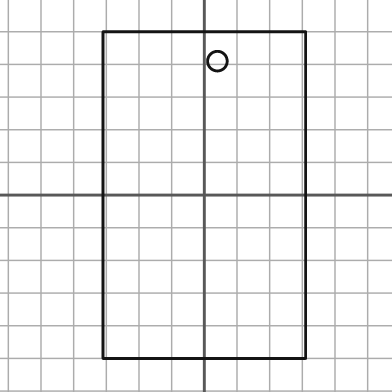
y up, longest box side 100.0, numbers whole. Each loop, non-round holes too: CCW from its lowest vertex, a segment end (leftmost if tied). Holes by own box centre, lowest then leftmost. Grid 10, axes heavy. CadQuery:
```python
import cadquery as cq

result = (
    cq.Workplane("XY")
    .moveTo(-31.0, -50.0)
    .lineTo(31.0, -50.0)
    .lineTo(31.0, 50.0)
    .lineTo(-31.0, 50.0)
    .close()
    .moveTo(4.0, 41.0)
    .circle(3.0)
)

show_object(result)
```